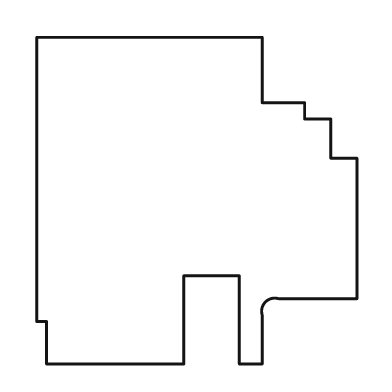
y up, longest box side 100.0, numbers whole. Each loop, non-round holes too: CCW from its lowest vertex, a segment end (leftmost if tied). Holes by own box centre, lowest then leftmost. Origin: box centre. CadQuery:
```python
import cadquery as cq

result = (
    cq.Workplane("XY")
    .moveTo(-46.0, -50.0)
    .lineTo(-4.0, -50.0)
    .lineTo(-4.0, -23.0)
    .lineTo(13.0, -23.0)
    .lineTo(13.0, -50.0)
    .lineTo(20.0, -50.0)
    .lineTo(20.0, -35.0)
    .threePointArc((21.0, -31.0), (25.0, -30.0))
    .lineTo(49.0, -30.0)
    .lineTo(49.0, 13.0)
    .lineTo(41.0, 13.0)
    .lineTo(41.0, 25.0)
    .lineTo(33.0, 25.0)
    .lineTo(33.0, 30.0)
    .lineTo(20.0, 30.0)
    .lineTo(20.0, 50.0)
    .lineTo(-49.0, 50.0)
    .lineTo(-49.0, -37.0)
    .lineTo(-46.0, -37.0)
    .close()
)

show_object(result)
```